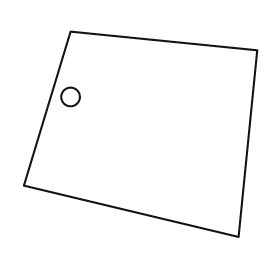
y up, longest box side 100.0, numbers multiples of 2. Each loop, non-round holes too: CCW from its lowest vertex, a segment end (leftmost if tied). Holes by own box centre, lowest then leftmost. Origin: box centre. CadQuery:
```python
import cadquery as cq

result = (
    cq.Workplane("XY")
    .moveTo(42.0, -44.0)
    .lineTo(50.0, 36.0)
    .lineTo(-30.0, 44.0)
    .lineTo(-50.0, -22.0)
    .close()
    .moveTo(-30.0, 16.0)
    .circle(4.0)
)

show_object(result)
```